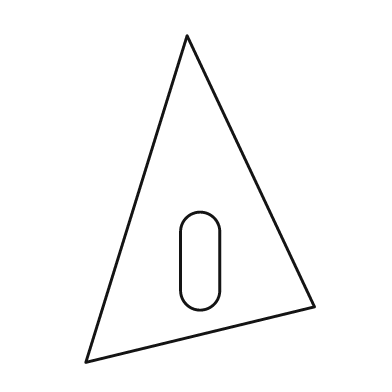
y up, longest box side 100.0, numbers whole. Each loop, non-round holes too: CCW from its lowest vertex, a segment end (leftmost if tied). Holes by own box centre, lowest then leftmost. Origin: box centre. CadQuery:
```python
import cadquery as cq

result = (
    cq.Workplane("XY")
    .moveTo(-35.0, -50.0)
    .lineTo(35.0, -33.0)
    .lineTo(-4.0, 50.0)
    .close()
    .moveTo(-6.0, -28.0)
    .threePointArc((0.0, -34.0), (6.0, -28.0))
    .lineTo(6.0, -10.0)
    .threePointArc((0.0, -4.0), (-6.0, -10.0))
    .close()
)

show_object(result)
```